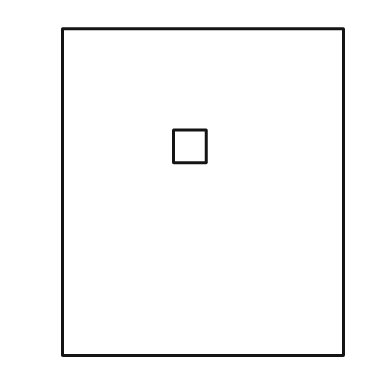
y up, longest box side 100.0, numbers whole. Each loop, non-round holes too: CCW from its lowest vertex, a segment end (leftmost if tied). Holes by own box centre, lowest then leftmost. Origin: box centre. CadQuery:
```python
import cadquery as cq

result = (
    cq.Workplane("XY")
    .moveTo(-43.0, -50.0)
    .lineTo(43.0, -50.0)
    .lineTo(43.0, 50.0)
    .lineTo(-43.0, 50.0)
    .close()
    .moveTo(-9.0, 9.0)
    .lineTo(1.0, 9.0)
    .lineTo(1.0, 19.0)
    .lineTo(-9.0, 19.0)
    .close()
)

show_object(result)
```